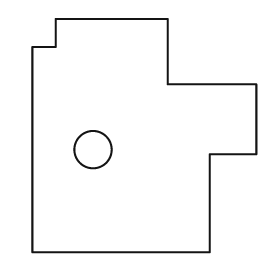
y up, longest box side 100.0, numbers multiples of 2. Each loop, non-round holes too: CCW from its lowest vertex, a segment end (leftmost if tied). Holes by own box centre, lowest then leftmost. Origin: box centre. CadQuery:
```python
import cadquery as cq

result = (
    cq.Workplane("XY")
    .moveTo(-48.0, -50.0)
    .lineTo(28.0, -50.0)
    .lineTo(28.0, -8.0)
    .lineTo(48.0, -8.0)
    .lineTo(48.0, 22.0)
    .lineTo(10.0, 22.0)
    .lineTo(10.0, 50.0)
    .lineTo(-38.0, 50.0)
    .lineTo(-38.0, 38.0)
    .lineTo(-48.0, 38.0)
    .close()
    .moveTo(-22.0, -6.0)
    .circle(8.0)
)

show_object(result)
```